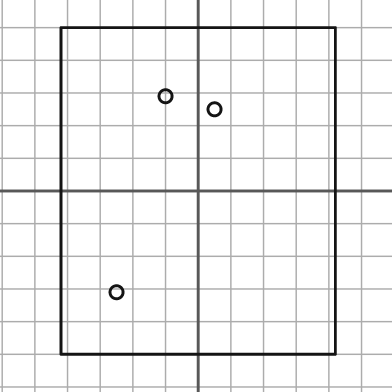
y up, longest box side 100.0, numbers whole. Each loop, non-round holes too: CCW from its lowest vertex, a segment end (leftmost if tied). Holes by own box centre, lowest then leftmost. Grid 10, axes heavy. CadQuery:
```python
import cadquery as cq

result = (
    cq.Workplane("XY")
    .moveTo(-42.0, -50.0)
    .lineTo(42.0, -50.0)
    .lineTo(42.0, 50.0)
    .lineTo(-42.0, 50.0)
    .close()
    .moveTo(-25.0, -31.0)
    .circle(2.0)
    .moveTo(5.0, 25.0)
    .circle(2.0)
    .moveTo(-10.0, 29.0)
    .circle(2.0)
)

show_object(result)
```